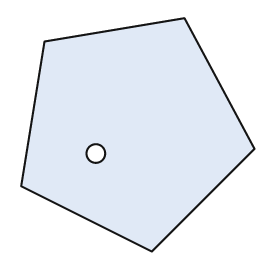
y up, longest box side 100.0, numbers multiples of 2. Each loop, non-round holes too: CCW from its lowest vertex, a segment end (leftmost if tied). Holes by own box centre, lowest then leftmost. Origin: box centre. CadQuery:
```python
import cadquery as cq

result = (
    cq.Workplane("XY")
    .moveTo(6.0, -50.0)
    .lineTo(50.0, -6.0)
    .lineTo(20.0, 50.0)
    .lineTo(-40.0, 40.0)
    .lineTo(-50.0, -22.0)
    .close()
    .moveTo(-18.0, -8.0)
    .circle(4.0)
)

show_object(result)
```